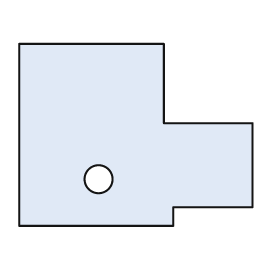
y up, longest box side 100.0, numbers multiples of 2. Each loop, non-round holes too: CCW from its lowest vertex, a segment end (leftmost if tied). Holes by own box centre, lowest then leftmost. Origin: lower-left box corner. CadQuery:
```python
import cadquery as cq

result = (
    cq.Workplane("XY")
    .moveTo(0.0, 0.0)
    .lineTo(66.0, 0.0)
    .lineTo(66.0, 8.0)
    .lineTo(100.0, 8.0)
    .lineTo(100.0, 44.0)
    .lineTo(62.0, 44.0)
    .lineTo(62.0, 78.0)
    .lineTo(0.0, 78.0)
    .close()
    .moveTo(34.0, 20.0)
    .circle(6.0)
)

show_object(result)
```